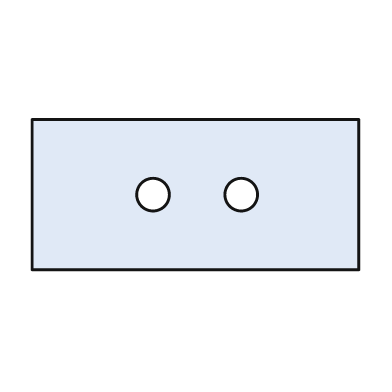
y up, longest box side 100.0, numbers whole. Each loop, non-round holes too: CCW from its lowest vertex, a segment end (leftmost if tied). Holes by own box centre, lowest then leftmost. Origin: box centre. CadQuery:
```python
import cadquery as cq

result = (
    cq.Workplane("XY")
    .moveTo(-50.0, -23.0)
    .lineTo(50.0, -23.0)
    .lineTo(50.0, 23.0)
    .lineTo(-50.0, 23.0)
    .close()
    .moveTo(-13.0, 0.0)
    .circle(5.0)
    .moveTo(14.0, 0.0)
    .circle(5.0)
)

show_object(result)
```